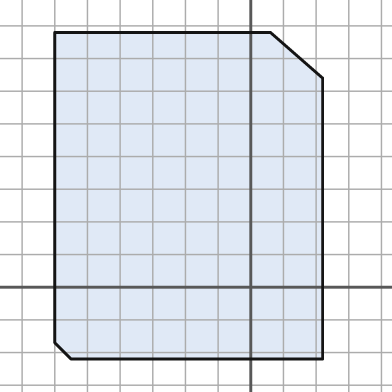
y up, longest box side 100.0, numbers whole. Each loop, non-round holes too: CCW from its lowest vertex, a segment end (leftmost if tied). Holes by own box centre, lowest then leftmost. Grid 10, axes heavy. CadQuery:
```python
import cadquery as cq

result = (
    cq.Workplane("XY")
    .moveTo(-55.0, -22.0)
    .lineTo(22.0, -22.0)
    .lineTo(22.0, 64.0)
    .lineTo(6.0, 78.0)
    .lineTo(-60.0, 78.0)
    .lineTo(-60.0, -17.0)
    .close()
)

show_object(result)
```